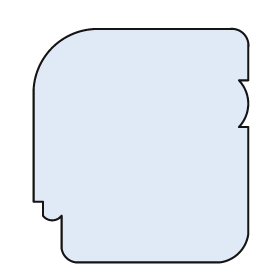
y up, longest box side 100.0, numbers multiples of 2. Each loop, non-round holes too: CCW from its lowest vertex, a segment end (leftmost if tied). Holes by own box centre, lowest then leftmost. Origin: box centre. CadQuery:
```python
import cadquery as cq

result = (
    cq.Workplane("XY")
    .moveTo(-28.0, -50.0)
    .lineTo(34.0, -50.0)
    .threePointArc((42.0, -46.0), (46.0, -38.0))
    .lineTo(46.0, 8.0)
    .lineTo(42.0, 8.0)
    .threePointArc((46.0, 18.0), (42.0, 28.0))
    .lineTo(46.0, 28.0)
    .lineTo(46.0, 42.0)
    .threePointArc((44.0, 48.0), (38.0, 50.0))
    .lineTo(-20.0, 50.0)
    .threePointArc((-38.0, 42.0), (-46.0, 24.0))
    .lineTo(-46.0, -24.0)
    .lineTo(-42.0, -24.0)
    .lineTo(-42.0, -30.0)
    .threePointArc((-38.0, -32.0), (-34.0, -30.0))
    .lineTo(-34.0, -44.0)
    .threePointArc((-32.0, -48.0), (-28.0, -50.0))
    .close()
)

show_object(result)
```